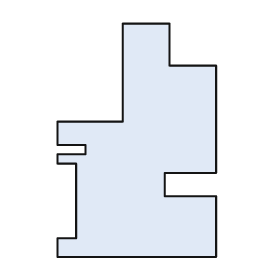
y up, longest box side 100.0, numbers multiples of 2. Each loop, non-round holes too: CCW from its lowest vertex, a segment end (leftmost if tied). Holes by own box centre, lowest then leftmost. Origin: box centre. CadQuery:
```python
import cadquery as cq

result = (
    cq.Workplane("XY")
    .moveTo(-34.0, -50.0)
    .lineTo(34.0, -50.0)
    .lineTo(34.0, -24.0)
    .lineTo(12.0, -24.0)
    .lineTo(12.0, -14.0)
    .lineTo(34.0, -14.0)
    .lineTo(34.0, 32.0)
    .lineTo(14.0, 32.0)
    .lineTo(14.0, 50.0)
    .lineTo(-6.0, 50.0)
    .lineTo(-6.0, 8.0)
    .lineTo(-34.0, 8.0)
    .lineTo(-34.0, -2.0)
    .lineTo(-22.0, -2.0)
    .lineTo(-22.0, -6.0)
    .lineTo(-34.0, -6.0)
    .lineTo(-34.0, -10.0)
    .lineTo(-26.0, -10.0)
    .lineTo(-26.0, -42.0)
    .lineTo(-34.0, -42.0)
    .close()
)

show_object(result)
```